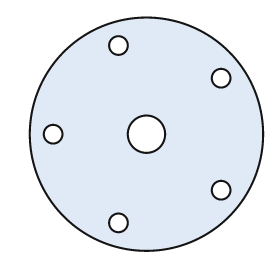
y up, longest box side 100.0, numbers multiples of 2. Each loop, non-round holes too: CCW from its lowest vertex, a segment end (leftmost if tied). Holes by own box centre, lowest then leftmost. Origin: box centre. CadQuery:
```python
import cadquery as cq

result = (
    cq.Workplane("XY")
    .moveTo(0.0, 0.0)
    .circle(50.0)
    .moveTo(-12.0, -38.0)
    .circle(4.0)
    .moveTo(32.0, -24.0)
    .circle(4.0)
    .moveTo(-40.0, 0.0)
    .circle(4.0)
    .moveTo(0.0, 0.0)
    .circle(8.0)
    .moveTo(32.0, 24.0)
    .circle(4.0)
    .moveTo(-12.0, 38.0)
    .circle(4.0)
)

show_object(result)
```